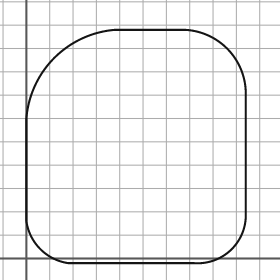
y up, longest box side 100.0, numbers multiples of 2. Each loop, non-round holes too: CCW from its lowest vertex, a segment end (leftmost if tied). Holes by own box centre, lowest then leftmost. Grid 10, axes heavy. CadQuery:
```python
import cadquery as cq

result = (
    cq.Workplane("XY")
    .moveTo(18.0, -2.0)
    .lineTo(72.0, -2.0)
    .threePointArc((88.0, 4.0), (94.0, 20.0))
    .lineTo(94.0, 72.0)
    .threePointArc((86.0, 90.0), (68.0, 98.0))
    .lineTo(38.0, 98.0)
    .threePointArc((12.0, 86.0), (0.0, 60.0))
    .lineTo(0.0, 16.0)
    .threePointArc((6.0, 4.0), (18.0, -2.0))
    .close()
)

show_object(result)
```